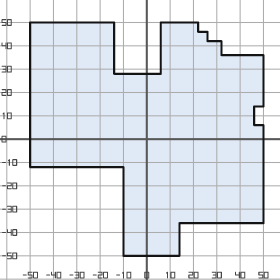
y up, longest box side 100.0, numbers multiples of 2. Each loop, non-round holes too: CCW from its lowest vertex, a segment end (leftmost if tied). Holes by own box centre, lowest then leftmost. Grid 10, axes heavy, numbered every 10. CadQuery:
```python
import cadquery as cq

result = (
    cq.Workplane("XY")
    .moveTo(-10.0, -50.0)
    .lineTo(14.0, -50.0)
    .lineTo(14.0, -36.0)
    .lineTo(50.0, -36.0)
    .lineTo(50.0, 6.0)
    .lineTo(46.0, 6.0)
    .lineTo(46.0, 14.0)
    .lineTo(50.0, 14.0)
    .lineTo(50.0, 36.0)
    .lineTo(32.0, 36.0)
    .lineTo(32.0, 42.0)
    .lineTo(26.0, 42.0)
    .lineTo(26.0, 46.0)
    .lineTo(22.0, 46.0)
    .lineTo(22.0, 50.0)
    .lineTo(6.0, 50.0)
    .lineTo(6.0, 28.0)
    .lineTo(-14.0, 28.0)
    .lineTo(-14.0, 50.0)
    .lineTo(-50.0, 50.0)
    .lineTo(-50.0, -12.0)
    .lineTo(-10.0, -12.0)
    .close()
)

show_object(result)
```